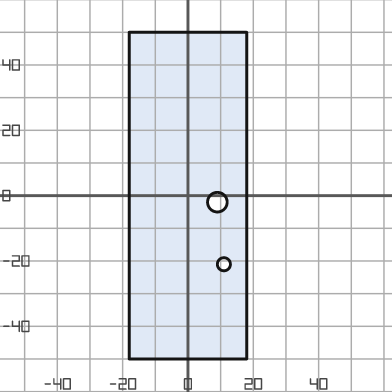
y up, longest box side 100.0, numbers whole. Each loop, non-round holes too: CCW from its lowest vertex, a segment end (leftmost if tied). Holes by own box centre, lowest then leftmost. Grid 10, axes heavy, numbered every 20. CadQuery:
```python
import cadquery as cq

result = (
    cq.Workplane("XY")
    .moveTo(-18.0, -50.0)
    .lineTo(18.0, -50.0)
    .lineTo(18.0, 50.0)
    .lineTo(-18.0, 50.0)
    .close()
    .moveTo(11.0, -21.0)
    .circle(2.0)
    .moveTo(9.0, -2.0)
    .circle(3.0)
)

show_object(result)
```